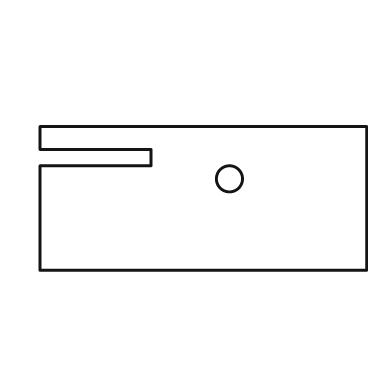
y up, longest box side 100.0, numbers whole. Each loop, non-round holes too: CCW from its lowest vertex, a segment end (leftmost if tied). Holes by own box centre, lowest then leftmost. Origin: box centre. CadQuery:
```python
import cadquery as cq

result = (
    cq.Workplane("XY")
    .moveTo(-50.0, -22.0)
    .lineTo(50.0, -22.0)
    .lineTo(50.0, 22.0)
    .lineTo(-50.0, 22.0)
    .lineTo(-50.0, 15.0)
    .lineTo(-16.0, 15.0)
    .lineTo(-16.0, 10.0)
    .lineTo(-50.0, 10.0)
    .close()
    .moveTo(8.0, 6.0)
    .circle(4.0)
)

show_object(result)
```